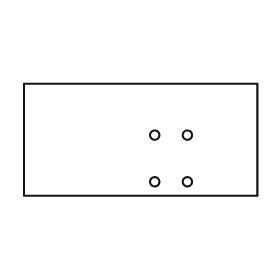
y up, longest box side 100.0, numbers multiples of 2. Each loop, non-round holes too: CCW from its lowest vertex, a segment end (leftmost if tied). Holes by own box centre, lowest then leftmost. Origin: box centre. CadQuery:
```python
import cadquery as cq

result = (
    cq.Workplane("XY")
    .moveTo(-50.0, -24.0)
    .lineTo(50.0, -24.0)
    .lineTo(50.0, 24.0)
    .lineTo(-50.0, 24.0)
    .close()
    .moveTo(6.0, -18.0)
    .circle(2.0)
    .moveTo(20.0, -18.0)
    .circle(2.0)
    .moveTo(6.0, 2.0)
    .circle(2.0)
    .moveTo(20.0, 2.0)
    .circle(2.0)
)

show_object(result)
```